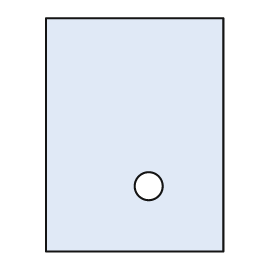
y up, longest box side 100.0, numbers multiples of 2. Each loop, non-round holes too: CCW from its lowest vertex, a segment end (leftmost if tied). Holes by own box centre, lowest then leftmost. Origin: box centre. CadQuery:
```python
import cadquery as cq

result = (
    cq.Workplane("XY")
    .moveTo(-38.0, -50.0)
    .lineTo(38.0, -50.0)
    .lineTo(38.0, 50.0)
    .lineTo(-38.0, 50.0)
    .close()
    .moveTo(6.0, -22.0)
    .circle(6.0)
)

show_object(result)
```